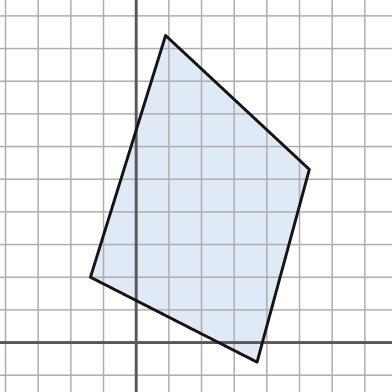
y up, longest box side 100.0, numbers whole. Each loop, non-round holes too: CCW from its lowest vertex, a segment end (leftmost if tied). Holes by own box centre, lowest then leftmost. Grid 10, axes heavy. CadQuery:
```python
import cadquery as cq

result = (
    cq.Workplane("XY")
    .moveTo(37.0, -6.0)
    .lineTo(53.0, 53.0)
    .lineTo(9.0, 94.0)
    .lineTo(-14.0, 20.0)
    .close()
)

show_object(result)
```